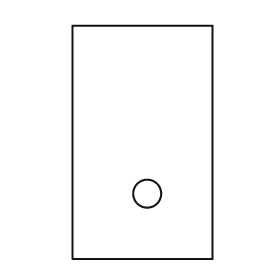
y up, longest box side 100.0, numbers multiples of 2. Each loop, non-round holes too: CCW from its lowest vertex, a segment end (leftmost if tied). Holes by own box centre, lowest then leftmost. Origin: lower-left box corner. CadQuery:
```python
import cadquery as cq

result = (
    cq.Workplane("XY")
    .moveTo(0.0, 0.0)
    .lineTo(60.0, 0.0)
    .lineTo(60.0, 100.0)
    .lineTo(0.0, 100.0)
    .close()
    .moveTo(32.0, 28.0)
    .circle(6.0)
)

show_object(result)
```